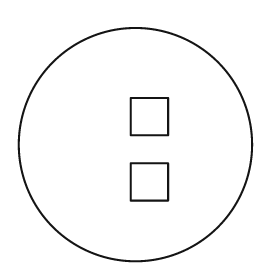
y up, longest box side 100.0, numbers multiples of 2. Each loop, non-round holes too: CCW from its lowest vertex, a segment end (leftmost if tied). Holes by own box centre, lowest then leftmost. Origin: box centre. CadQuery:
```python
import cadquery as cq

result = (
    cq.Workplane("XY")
    .moveTo(0.0, 0.0)
    .circle(50.0)
    .moveTo(-2.0, -24.0)
    .lineTo(14.0, -24.0)
    .lineTo(14.0, -8.0)
    .lineTo(-2.0, -8.0)
    .close()
    .moveTo(-2.0, 4.0)
    .lineTo(14.0, 4.0)
    .lineTo(14.0, 20.0)
    .lineTo(-2.0, 20.0)
    .close()
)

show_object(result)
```